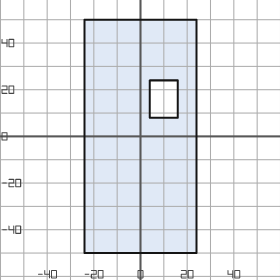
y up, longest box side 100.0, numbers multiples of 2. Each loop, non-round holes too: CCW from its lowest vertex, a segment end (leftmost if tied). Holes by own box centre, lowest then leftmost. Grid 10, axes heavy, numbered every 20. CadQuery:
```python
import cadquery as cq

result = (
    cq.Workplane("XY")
    .moveTo(-24.0, -50.0)
    .lineTo(24.0, -50.0)
    .lineTo(24.0, 50.0)
    .lineTo(-24.0, 50.0)
    .close()
    .moveTo(4.0, 8.0)
    .lineTo(16.0, 8.0)
    .lineTo(16.0, 24.0)
    .lineTo(4.0, 24.0)
    .close()
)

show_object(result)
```